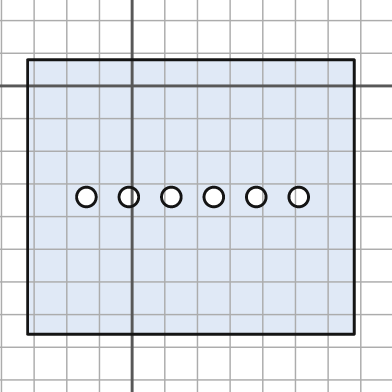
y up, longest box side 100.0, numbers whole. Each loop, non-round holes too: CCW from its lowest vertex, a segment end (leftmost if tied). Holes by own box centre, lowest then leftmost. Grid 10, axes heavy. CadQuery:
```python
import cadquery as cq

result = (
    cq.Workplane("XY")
    .moveTo(-32.0, -76.0)
    .lineTo(68.0, -76.0)
    .lineTo(68.0, 8.0)
    .lineTo(-32.0, 8.0)
    .close()
    .moveTo(-14.0, -34.0)
    .circle(3.0)
    .moveTo(-1.0, -34.0)
    .circle(3.0)
    .moveTo(12.0, -34.0)
    .circle(3.0)
    .moveTo(25.0, -34.0)
    .circle(3.0)
    .moveTo(38.0, -34.0)
    .circle(3.0)
    .moveTo(51.0, -34.0)
    .circle(3.0)
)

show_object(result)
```